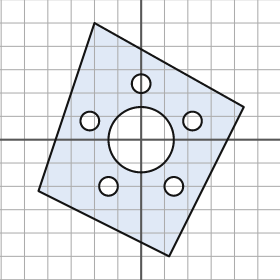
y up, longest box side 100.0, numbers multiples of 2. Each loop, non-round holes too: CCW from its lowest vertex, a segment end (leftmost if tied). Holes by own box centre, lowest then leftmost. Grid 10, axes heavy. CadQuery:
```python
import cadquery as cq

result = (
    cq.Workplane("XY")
    .moveTo(12.0, -50.0)
    .lineTo(44.0, 14.0)
    .lineTo(-20.0, 50.0)
    .lineTo(-44.0, -22.0)
    .close()
    .moveTo(-14.0, -20.0)
    .circle(4.0)
    .moveTo(14.0, -20.0)
    .circle(4.0)
    .moveTo(0.0, 0.0)
    .circle(14.0)
    .moveTo(-22.0, 8.0)
    .circle(4.0)
    .moveTo(22.0, 8.0)
    .circle(4.0)
    .moveTo(0.0, 24.0)
    .circle(4.0)
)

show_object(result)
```